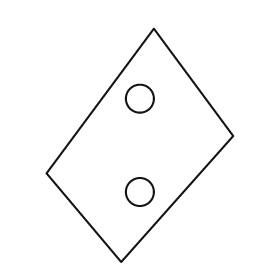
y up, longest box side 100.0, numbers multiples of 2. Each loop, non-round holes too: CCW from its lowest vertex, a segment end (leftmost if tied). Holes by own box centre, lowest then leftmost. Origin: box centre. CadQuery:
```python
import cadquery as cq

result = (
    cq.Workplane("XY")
    .moveTo(-8.0, -50.0)
    .lineTo(40.0, 4.0)
    .lineTo(6.0, 50.0)
    .lineTo(-40.0, -12.0)
    .close()
    .moveTo(0.0, -20.0)
    .circle(6.0)
    .moveTo(0.0, 20.0)
    .circle(6.0)
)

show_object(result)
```